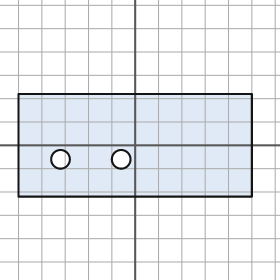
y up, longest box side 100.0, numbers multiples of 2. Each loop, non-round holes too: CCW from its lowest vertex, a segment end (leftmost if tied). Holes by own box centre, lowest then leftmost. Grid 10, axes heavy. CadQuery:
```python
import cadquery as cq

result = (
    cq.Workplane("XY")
    .moveTo(-50.0, -22.0)
    .lineTo(50.0, -22.0)
    .lineTo(50.0, 22.0)
    .lineTo(-50.0, 22.0)
    .close()
    .moveTo(-32.0, -6.0)
    .circle(4.0)
    .moveTo(-6.0, -6.0)
    .circle(4.0)
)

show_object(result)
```